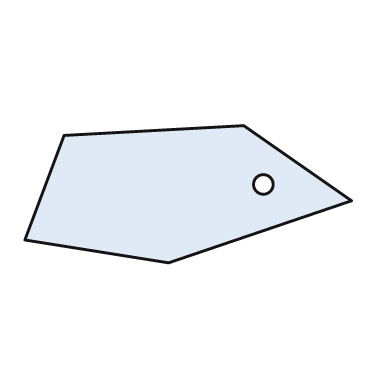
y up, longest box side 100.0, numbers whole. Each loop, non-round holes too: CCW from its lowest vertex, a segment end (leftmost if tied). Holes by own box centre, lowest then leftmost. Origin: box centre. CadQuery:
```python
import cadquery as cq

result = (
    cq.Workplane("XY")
    .moveTo(-6.0, -21.0)
    .lineTo(50.0, -2.0)
    .lineTo(17.0, 21.0)
    .lineTo(-38.0, 18.0)
    .lineTo(-50.0, -14.0)
    .close()
    .moveTo(23.0, 3.0)
    .circle(3.0)
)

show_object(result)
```